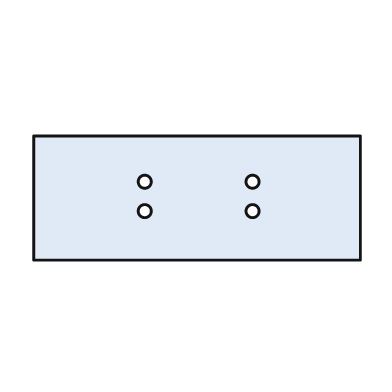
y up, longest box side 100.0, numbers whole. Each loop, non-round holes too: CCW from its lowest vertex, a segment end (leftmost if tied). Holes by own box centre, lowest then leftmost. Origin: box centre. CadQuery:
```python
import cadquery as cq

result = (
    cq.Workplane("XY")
    .moveTo(-50.0, -19.0)
    .lineTo(50.0, -19.0)
    .lineTo(50.0, 19.0)
    .lineTo(-50.0, 19.0)
    .close()
    .moveTo(-16.0, -4.0)
    .circle(2.0)
    .moveTo(17.0, -4.0)
    .circle(2.0)
    .moveTo(-16.0, 5.0)
    .circle(2.0)
    .moveTo(17.0, 5.0)
    .circle(2.0)
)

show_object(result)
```